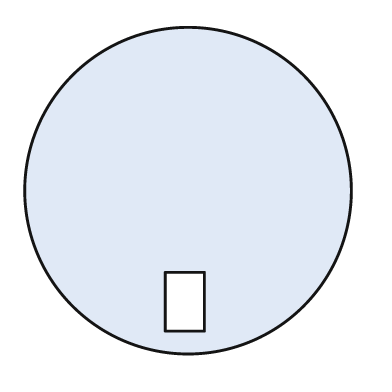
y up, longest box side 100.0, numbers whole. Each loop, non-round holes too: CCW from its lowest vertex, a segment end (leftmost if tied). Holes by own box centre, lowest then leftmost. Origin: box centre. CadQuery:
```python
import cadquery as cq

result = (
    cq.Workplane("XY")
    .moveTo(0.0, 0.0)
    .circle(50.0)
    .moveTo(-7.0, -43.0)
    .lineTo(5.0, -43.0)
    .lineTo(5.0, -25.0)
    .lineTo(-7.0, -25.0)
    .close()
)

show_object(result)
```